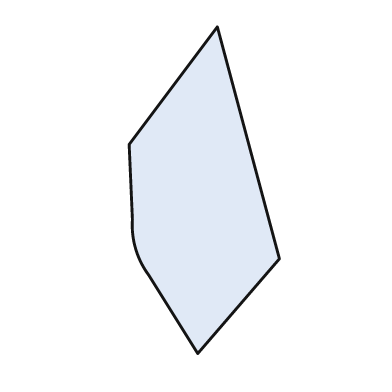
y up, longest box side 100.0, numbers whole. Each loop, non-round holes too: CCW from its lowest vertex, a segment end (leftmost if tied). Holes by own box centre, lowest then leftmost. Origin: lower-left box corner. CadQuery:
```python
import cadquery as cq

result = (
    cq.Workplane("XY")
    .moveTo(21.0, 0.0)
    .lineTo(46.0, 29.0)
    .lineTo(27.0, 100.0)
    .lineTo(0.0, 64.0)
    .lineTo(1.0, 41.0)
    .threePointArc((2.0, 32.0), (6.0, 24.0))
    .close()
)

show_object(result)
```